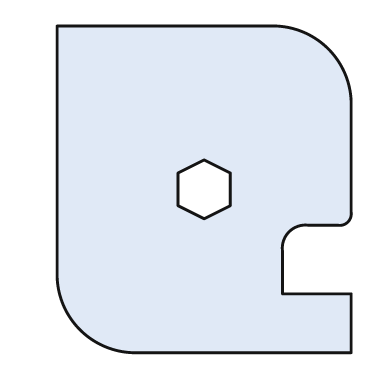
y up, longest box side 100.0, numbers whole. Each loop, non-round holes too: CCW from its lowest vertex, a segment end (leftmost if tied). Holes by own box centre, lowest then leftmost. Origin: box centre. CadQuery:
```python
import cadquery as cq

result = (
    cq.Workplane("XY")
    .moveTo(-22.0, -50.0)
    .lineTo(45.0, -50.0)
    .lineTo(45.0, -32.0)
    .lineTo(24.0, -32.0)
    .lineTo(24.0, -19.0)
    .threePointArc((26.0, -13.0), (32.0, -11.0))
    .lineTo(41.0, -11.0)
    .threePointArc((44.0, -10.0), (45.0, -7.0))
    .lineTo(45.0, 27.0)
    .threePointArc((38.0, 43.0), (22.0, 50.0))
    .lineTo(-45.0, 50.0)
    .lineTo(-45.0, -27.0)
    .threePointArc((-38.0, -43.0), (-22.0, -50.0))
    .close()
    .moveTo(0.0, -9.0)
    .lineTo(8.0, -5.0)
    .lineTo(8.0, 5.0)
    .lineTo(0.0, 9.0)
    .lineTo(-8.0, 5.0)
    .lineTo(-8.0, -5.0)
    .close()
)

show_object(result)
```